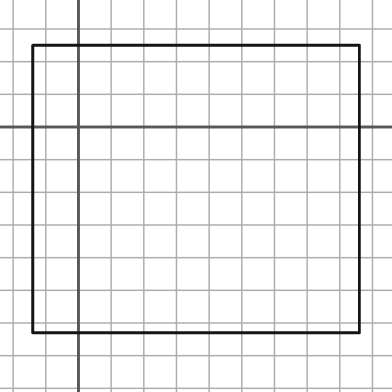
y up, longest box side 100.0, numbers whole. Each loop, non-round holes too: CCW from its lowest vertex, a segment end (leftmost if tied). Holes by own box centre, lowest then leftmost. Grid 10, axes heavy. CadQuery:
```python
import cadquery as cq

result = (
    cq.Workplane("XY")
    .moveTo(-14.0, -63.0)
    .lineTo(86.0, -63.0)
    .lineTo(86.0, 25.0)
    .lineTo(-14.0, 25.0)
    .close()
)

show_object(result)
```